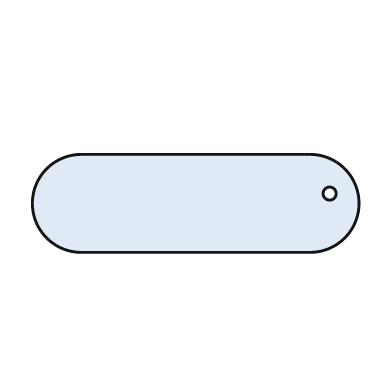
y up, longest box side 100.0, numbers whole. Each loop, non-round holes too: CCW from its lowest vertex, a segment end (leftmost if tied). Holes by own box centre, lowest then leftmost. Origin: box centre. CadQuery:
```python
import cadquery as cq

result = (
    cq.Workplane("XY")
    .moveTo(-35.0, -15.0)
    .lineTo(35.0, -15.0)
    .threePointArc((50.0, 0.0), (35.0, 15.0))
    .lineTo(-35.0, 15.0)
    .threePointArc((-50.0, 0.0), (-35.0, -15.0))
    .close()
    .moveTo(41.0, 3.0)
    .circle(2.0)
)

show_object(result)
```